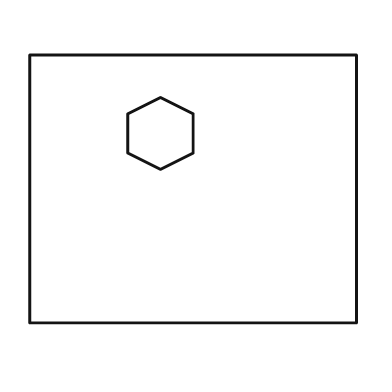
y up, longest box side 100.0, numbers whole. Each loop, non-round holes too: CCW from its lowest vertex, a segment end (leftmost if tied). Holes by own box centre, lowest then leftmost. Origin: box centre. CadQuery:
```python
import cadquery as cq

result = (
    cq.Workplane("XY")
    .moveTo(-50.0, -41.0)
    .lineTo(50.0, -41.0)
    .lineTo(50.0, 41.0)
    .lineTo(-50.0, 41.0)
    .close()
    .moveTo(-10.0, 6.0)
    .lineTo(0.0, 11.0)
    .lineTo(0.0, 23.0)
    .lineTo(-10.0, 28.0)
    .lineTo(-20.0, 23.0)
    .lineTo(-20.0, 11.0)
    .close()
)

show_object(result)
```